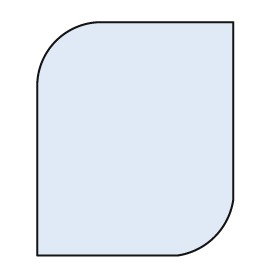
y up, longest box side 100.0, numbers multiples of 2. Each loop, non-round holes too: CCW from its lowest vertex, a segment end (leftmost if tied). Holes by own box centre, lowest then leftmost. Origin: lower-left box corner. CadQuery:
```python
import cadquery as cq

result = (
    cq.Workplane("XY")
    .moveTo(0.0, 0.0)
    .lineTo(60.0, 0.0)
    .threePointArc((76.0, 8.0), (84.0, 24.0))
    .lineTo(84.0, 100.0)
    .lineTo(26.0, 100.0)
    .threePointArc((8.0, 92.0), (0.0, 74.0))
    .close()
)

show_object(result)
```